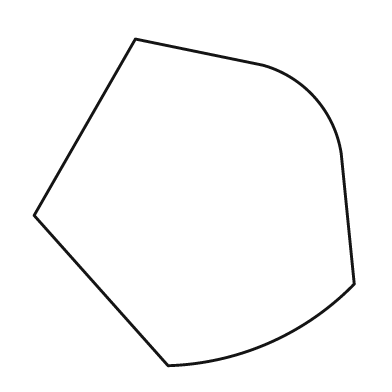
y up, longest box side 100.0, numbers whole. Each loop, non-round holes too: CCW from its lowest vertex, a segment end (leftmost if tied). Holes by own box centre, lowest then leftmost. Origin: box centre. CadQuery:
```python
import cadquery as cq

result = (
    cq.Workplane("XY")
    .moveTo(-8.0, -50.0)
    .threePointArc((23.0, -43.0), (49.0, -25.0))
    .lineTo(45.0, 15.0)
    .threePointArc((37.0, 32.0), (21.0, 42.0))
    .lineTo(-18.0, 50.0)
    .lineTo(-49.0, -4.0)
    .close()
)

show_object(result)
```